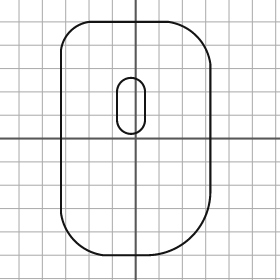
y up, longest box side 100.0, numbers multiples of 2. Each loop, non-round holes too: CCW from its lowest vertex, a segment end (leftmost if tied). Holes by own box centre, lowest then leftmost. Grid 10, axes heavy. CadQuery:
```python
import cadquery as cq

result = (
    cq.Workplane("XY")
    .moveTo(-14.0, -50.0)
    .lineTo(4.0, -50.0)
    .threePointArc((24.0, -42.0), (32.0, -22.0))
    .lineTo(32.0, 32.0)
    .threePointArc((26.0, 44.0), (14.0, 50.0))
    .lineTo(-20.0, 50.0)
    .threePointArc((-28.0, 46.0), (-32.0, 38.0))
    .lineTo(-32.0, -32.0)
    .threePointArc((-26.0, -44.0), (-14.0, -50.0))
    .close()
    .moveTo(-8.0, 8.0)
    .threePointArc((-2.0, 2.0), (4.0, 8.0))
    .lineTo(4.0, 20.0)
    .threePointArc((-2.0, 26.0), (-8.0, 20.0))
    .close()
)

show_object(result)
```